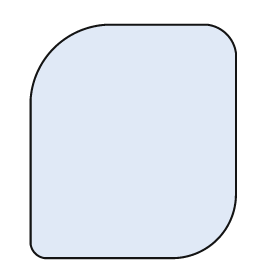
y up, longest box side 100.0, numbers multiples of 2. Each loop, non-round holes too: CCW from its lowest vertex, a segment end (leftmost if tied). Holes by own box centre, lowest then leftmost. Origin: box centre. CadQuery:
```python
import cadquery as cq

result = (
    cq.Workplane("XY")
    .moveTo(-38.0, -50.0)
    .lineTo(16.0, -50.0)
    .threePointArc((36.0, -42.0), (44.0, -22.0))
    .lineTo(44.0, 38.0)
    .threePointArc((40.0, 46.0), (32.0, 50.0))
    .lineTo(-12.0, 50.0)
    .threePointArc((-34.0, 40.0), (-44.0, 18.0))
    .lineTo(-44.0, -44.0)
    .threePointArc((-42.0, -48.0), (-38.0, -50.0))
    .close()
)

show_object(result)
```